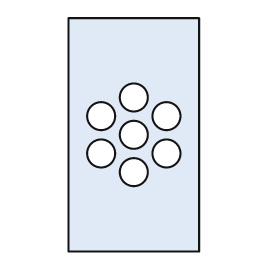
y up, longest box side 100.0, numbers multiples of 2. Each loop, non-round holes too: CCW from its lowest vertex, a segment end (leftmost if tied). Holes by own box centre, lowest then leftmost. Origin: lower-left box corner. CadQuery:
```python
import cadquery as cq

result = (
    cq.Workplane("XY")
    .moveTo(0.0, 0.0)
    .lineTo(56.0, 0.0)
    .lineTo(56.0, 100.0)
    .lineTo(0.0, 100.0)
    .close()
    .moveTo(28.0, 34.0)
    .circle(6.0)
    .moveTo(14.0, 42.0)
    .circle(6.0)
    .moveTo(42.0, 42.0)
    .circle(6.0)
    .moveTo(28.0, 50.0)
    .circle(6.0)
    .moveTo(14.0, 58.0)
    .circle(6.0)
    .moveTo(42.0, 58.0)
    .circle(6.0)
    .moveTo(28.0, 66.0)
    .circle(6.0)
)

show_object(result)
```